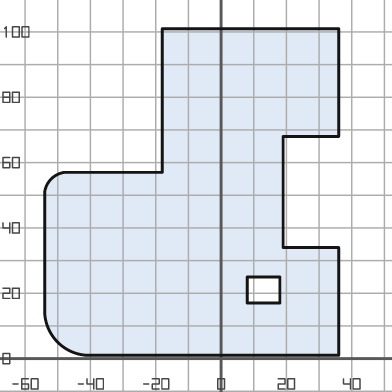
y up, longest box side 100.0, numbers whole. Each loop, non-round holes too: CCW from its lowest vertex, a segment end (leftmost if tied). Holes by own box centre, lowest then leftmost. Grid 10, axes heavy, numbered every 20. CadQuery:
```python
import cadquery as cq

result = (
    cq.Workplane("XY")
    .moveTo(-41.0, 1.0)
    .lineTo(36.0, 1.0)
    .lineTo(36.0, 34.0)
    .lineTo(19.0, 34.0)
    .lineTo(19.0, 68.0)
    .lineTo(36.0, 68.0)
    .lineTo(36.0, 101.0)
    .lineTo(-18.0, 101.0)
    .lineTo(-18.0, 57.0)
    .lineTo(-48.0, 57.0)
    .threePointArc((-52.0, 55.0), (-54.0, 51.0))
    .lineTo(-54.0, 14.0)
    .threePointArc((-50.0, 5.0), (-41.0, 1.0))
    .close()
    .moveTo(8.0, 17.0)
    .lineTo(18.0, 17.0)
    .lineTo(18.0, 25.0)
    .lineTo(8.0, 25.0)
    .close()
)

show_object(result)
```